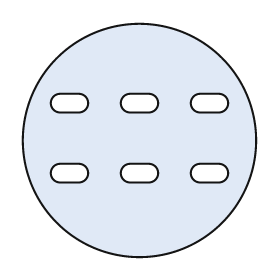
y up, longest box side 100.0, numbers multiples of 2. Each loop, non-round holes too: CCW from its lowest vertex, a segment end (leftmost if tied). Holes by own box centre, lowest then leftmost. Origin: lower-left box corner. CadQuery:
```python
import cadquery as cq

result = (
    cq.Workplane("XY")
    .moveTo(50.0, 50.0)
    .circle(50.0)
    .moveTo(16.0, 32.0)
    .lineTo(24.0, 32.0)
    .threePointArc((28.0, 36.0), (24.0, 40.0))
    .lineTo(16.0, 40.0)
    .threePointArc((12.0, 36.0), (16.0, 32.0))
    .close()
    .moveTo(46.0, 32.0)
    .lineTo(54.0, 32.0)
    .threePointArc((58.0, 36.0), (54.0, 40.0))
    .lineTo(46.0, 40.0)
    .threePointArc((42.0, 36.0), (46.0, 32.0))
    .close()
    .moveTo(76.0, 32.0)
    .lineTo(84.0, 32.0)
    .threePointArc((88.0, 36.0), (84.0, 40.0))
    .lineTo(76.0, 40.0)
    .threePointArc((72.0, 36.0), (76.0, 32.0))
    .close()
    .moveTo(16.0, 62.0)
    .lineTo(24.0, 62.0)
    .threePointArc((28.0, 66.0), (24.0, 70.0))
    .lineTo(16.0, 70.0)
    .threePointArc((12.0, 66.0), (16.0, 62.0))
    .close()
    .moveTo(46.0, 62.0)
    .lineTo(54.0, 62.0)
    .threePointArc((58.0, 66.0), (54.0, 70.0))
    .lineTo(46.0, 70.0)
    .threePointArc((42.0, 66.0), (46.0, 62.0))
    .close()
    .moveTo(76.0, 62.0)
    .lineTo(84.0, 62.0)
    .threePointArc((88.0, 66.0), (84.0, 70.0))
    .lineTo(76.0, 70.0)
    .threePointArc((72.0, 66.0), (76.0, 62.0))
    .close()
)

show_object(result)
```